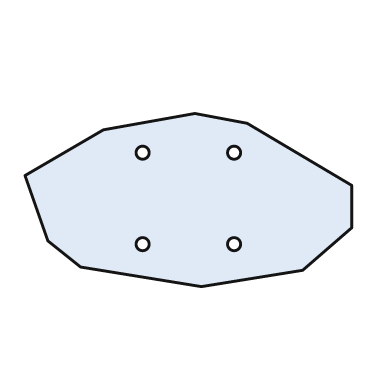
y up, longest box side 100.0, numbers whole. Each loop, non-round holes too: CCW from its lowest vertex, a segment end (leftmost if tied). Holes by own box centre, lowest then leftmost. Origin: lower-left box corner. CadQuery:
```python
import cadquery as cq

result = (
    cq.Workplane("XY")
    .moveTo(54.0, 0.0)
    .lineTo(85.0, 5.0)
    .lineTo(100.0, 18.0)
    .lineTo(100.0, 31.0)
    .lineTo(68.0, 50.0)
    .lineTo(52.0, 53.0)
    .lineTo(24.0, 48.0)
    .lineTo(0.0, 34.0)
    .lineTo(7.0, 14.0)
    .lineTo(17.0, 6.0)
    .close()
    .moveTo(36.0, 13.0)
    .circle(2.0)
    .moveTo(64.0, 13.0)
    .circle(2.0)
    .moveTo(36.0, 41.0)
    .circle(2.0)
    .moveTo(64.0, 41.0)
    .circle(2.0)
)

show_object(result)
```